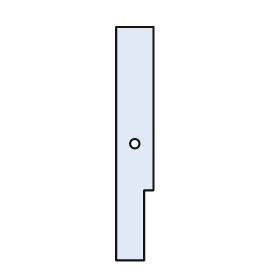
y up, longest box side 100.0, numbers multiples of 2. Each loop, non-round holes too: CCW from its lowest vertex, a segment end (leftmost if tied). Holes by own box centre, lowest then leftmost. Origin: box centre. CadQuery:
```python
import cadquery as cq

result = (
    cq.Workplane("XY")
    .moveTo(-8.0, -50.0)
    .lineTo(4.0, -50.0)
    .lineTo(4.0, -20.0)
    .lineTo(8.0, -20.0)
    .lineTo(8.0, 50.0)
    .lineTo(-8.0, 50.0)
    .close()
    .moveTo(0.0, 0.0)
    .circle(2.0)
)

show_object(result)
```